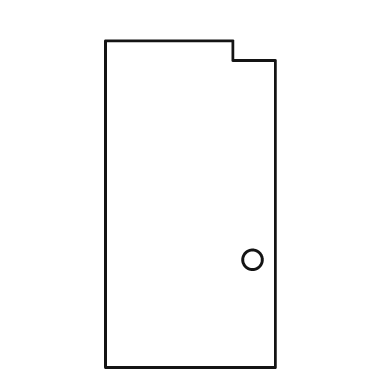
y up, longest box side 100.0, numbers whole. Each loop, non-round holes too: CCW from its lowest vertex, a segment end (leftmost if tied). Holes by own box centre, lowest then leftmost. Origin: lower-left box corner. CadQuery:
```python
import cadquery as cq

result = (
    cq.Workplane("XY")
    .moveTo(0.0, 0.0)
    .lineTo(52.0, 0.0)
    .lineTo(52.0, 94.0)
    .lineTo(39.0, 94.0)
    .lineTo(39.0, 100.0)
    .lineTo(0.0, 100.0)
    .close()
    .moveTo(45.0, 33.0)
    .circle(3.0)
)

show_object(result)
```